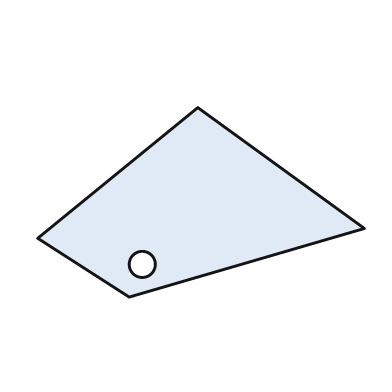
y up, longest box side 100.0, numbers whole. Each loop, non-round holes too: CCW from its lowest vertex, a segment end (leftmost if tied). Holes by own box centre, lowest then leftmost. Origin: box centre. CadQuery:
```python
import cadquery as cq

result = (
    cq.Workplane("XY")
    .moveTo(-22.0, -29.0)
    .lineTo(50.0, -8.0)
    .lineTo(-1.0, 29.0)
    .lineTo(-50.0, -11.0)
    .close()
    .moveTo(-18.0, -19.0)
    .circle(4.0)
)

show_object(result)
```